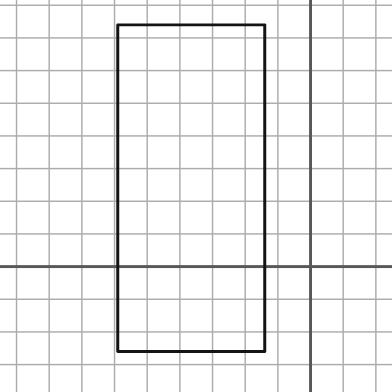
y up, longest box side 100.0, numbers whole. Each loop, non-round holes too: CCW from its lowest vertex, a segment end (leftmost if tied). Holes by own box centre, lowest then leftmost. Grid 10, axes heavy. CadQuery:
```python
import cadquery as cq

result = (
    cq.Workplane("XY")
    .moveTo(-59.0, -26.0)
    .lineTo(-14.0, -26.0)
    .lineTo(-14.0, 74.0)
    .lineTo(-59.0, 74.0)
    .close()
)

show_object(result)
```